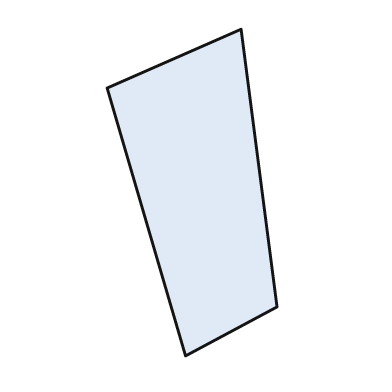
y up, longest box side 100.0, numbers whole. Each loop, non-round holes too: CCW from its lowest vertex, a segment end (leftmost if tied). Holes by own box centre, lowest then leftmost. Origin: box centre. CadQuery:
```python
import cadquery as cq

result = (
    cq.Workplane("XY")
    .moveTo(-2.0, -50.0)
    .lineTo(26.0, -35.0)
    .lineTo(15.0, 50.0)
    .lineTo(-26.0, 32.0)
    .close()
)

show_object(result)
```